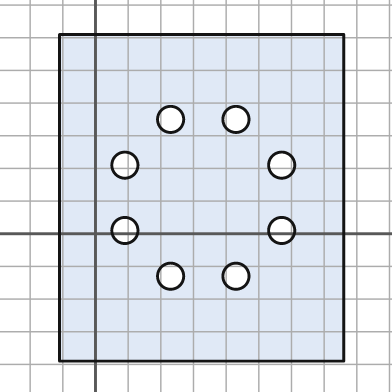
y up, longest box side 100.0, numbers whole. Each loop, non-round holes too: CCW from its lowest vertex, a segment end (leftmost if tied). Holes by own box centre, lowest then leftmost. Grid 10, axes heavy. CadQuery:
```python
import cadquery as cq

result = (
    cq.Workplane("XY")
    .moveTo(-11.0, -39.0)
    .lineTo(76.0, -39.0)
    .lineTo(76.0, 61.0)
    .lineTo(-11.0, 61.0)
    .close()
    .moveTo(23.0, -13.0)
    .circle(4.0)
    .moveTo(43.0, -13.0)
    .circle(4.0)
    .moveTo(9.0, 1.0)
    .circle(4.0)
    .moveTo(57.0, 1.0)
    .circle(4.0)
    .moveTo(9.0, 21.0)
    .circle(4.0)
    .moveTo(57.0, 21.0)
    .circle(4.0)
    .moveTo(23.0, 35.0)
    .circle(4.0)
    .moveTo(43.0, 35.0)
    .circle(4.0)
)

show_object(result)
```